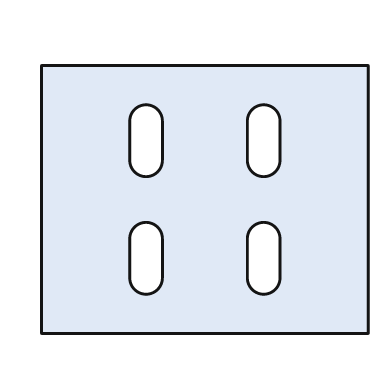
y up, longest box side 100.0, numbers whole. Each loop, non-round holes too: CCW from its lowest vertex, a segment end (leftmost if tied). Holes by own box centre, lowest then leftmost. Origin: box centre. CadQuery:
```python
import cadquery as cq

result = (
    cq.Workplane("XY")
    .moveTo(-50.0, -41.0)
    .lineTo(50.0, -41.0)
    .lineTo(50.0, 41.0)
    .lineTo(-50.0, 41.0)
    .close()
    .moveTo(-23.0, -24.0)
    .threePointArc((-18.0, -29.0), (-13.0, -24.0))
    .lineTo(-13.0, -12.0)
    .threePointArc((-18.0, -7.0), (-23.0, -12.0))
    .close()
    .moveTo(13.0, -24.0)
    .threePointArc((18.0, -29.0), (23.0, -24.0))
    .lineTo(23.0, -12.0)
    .threePointArc((18.0, -7.0), (13.0, -12.0))
    .close()
    .moveTo(-23.0, 12.0)
    .threePointArc((-18.0, 7.0), (-13.0, 12.0))
    .lineTo(-13.0, 24.0)
    .threePointArc((-18.0, 29.0), (-23.0, 24.0))
    .close()
    .moveTo(13.0, 12.0)
    .threePointArc((18.0, 7.0), (23.0, 12.0))
    .lineTo(23.0, 24.0)
    .threePointArc((18.0, 29.0), (13.0, 24.0))
    .close()
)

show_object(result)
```